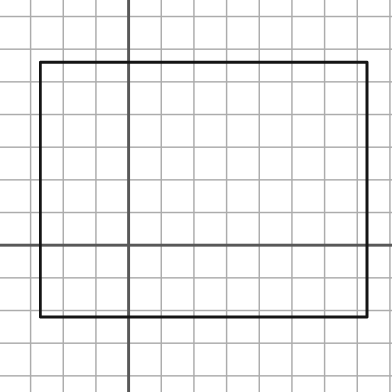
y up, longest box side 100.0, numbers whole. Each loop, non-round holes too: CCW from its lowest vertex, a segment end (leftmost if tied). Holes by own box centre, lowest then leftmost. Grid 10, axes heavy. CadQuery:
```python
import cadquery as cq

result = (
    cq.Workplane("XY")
    .moveTo(-27.0, -22.0)
    .lineTo(73.0, -22.0)
    .lineTo(73.0, 56.0)
    .lineTo(-27.0, 56.0)
    .close()
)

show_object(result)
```